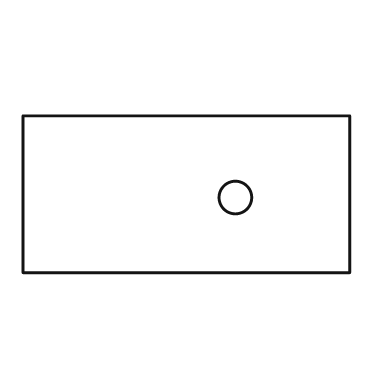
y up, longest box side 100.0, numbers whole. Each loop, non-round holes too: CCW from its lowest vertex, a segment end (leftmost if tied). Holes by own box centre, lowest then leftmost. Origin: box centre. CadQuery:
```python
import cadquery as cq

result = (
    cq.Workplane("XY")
    .moveTo(-50.0, -24.0)
    .lineTo(50.0, -24.0)
    .lineTo(50.0, 24.0)
    .lineTo(-50.0, 24.0)
    .close()
    .moveTo(15.0, -1.0)
    .circle(5.0)
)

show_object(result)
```